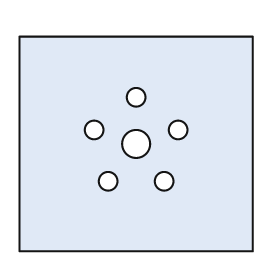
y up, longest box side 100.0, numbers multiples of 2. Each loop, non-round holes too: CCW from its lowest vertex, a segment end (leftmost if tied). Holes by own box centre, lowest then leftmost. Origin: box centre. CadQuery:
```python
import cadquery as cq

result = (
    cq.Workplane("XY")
    .moveTo(-50.0, -46.0)
    .lineTo(50.0, -46.0)
    .lineTo(50.0, 46.0)
    .lineTo(-50.0, 46.0)
    .close()
    .moveTo(-12.0, -16.0)
    .circle(4.0)
    .moveTo(12.0, -16.0)
    .circle(4.0)
    .moveTo(0.0, 0.0)
    .circle(6.0)
    .moveTo(-18.0, 6.0)
    .circle(4.0)
    .moveTo(18.0, 6.0)
    .circle(4.0)
    .moveTo(0.0, 20.0)
    .circle(4.0)
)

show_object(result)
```